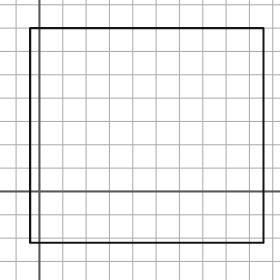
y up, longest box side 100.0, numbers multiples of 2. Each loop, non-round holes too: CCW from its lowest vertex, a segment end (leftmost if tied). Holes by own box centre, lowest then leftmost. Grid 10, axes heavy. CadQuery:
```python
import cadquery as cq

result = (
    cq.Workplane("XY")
    .moveTo(-4.0, -22.0)
    .lineTo(96.0, -22.0)
    .lineTo(96.0, 70.0)
    .lineTo(-4.0, 70.0)
    .close()
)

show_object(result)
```